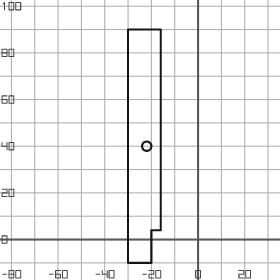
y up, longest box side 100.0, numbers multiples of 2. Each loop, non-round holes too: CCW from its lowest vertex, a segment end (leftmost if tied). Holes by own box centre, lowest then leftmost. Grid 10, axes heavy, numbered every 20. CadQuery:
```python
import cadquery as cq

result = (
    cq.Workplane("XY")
    .moveTo(-30.0, -10.0)
    .lineTo(-20.0, -10.0)
    .lineTo(-20.0, 4.0)
    .lineTo(-16.0, 4.0)
    .lineTo(-16.0, 90.0)
    .lineTo(-30.0, 90.0)
    .close()
    .moveTo(-22.0, 40.0)
    .circle(2.0)
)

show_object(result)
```